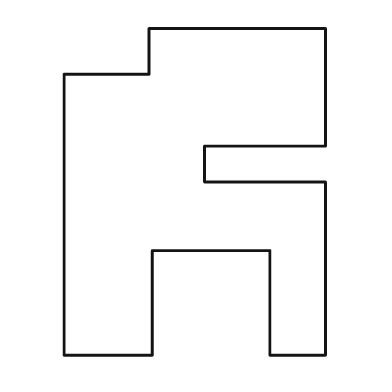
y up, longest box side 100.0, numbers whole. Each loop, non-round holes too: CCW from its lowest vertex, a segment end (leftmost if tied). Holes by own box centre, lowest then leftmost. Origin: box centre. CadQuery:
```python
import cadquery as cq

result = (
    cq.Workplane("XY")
    .moveTo(-40.0, -50.0)
    .lineTo(-13.0, -50.0)
    .lineTo(-13.0, -18.0)
    .lineTo(23.0, -18.0)
    .lineTo(23.0, -50.0)
    .lineTo(40.0, -50.0)
    .lineTo(40.0, 3.0)
    .lineTo(3.0, 3.0)
    .lineTo(3.0, 14.0)
    .lineTo(40.0, 14.0)
    .lineTo(40.0, 50.0)
    .lineTo(-14.0, 50.0)
    .lineTo(-14.0, 36.0)
    .lineTo(-40.0, 36.0)
    .close()
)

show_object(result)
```